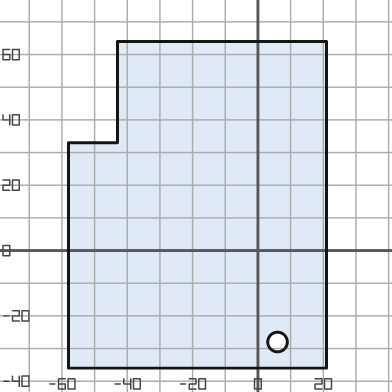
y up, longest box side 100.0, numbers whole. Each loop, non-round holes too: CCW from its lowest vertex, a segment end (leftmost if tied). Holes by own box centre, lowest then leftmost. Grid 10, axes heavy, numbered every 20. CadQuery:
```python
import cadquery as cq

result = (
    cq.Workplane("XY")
    .moveTo(-58.0, -36.0)
    .lineTo(21.0, -36.0)
    .lineTo(21.0, 64.0)
    .lineTo(-43.0, 64.0)
    .lineTo(-43.0, 33.0)
    .lineTo(-58.0, 33.0)
    .close()
    .moveTo(6.0, -28.0)
    .circle(3.0)
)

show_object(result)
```